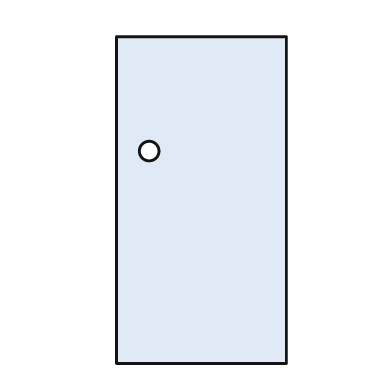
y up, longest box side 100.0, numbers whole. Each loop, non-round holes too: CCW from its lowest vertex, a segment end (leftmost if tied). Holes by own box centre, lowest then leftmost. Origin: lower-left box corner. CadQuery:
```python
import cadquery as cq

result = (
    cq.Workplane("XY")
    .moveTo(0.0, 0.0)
    .lineTo(52.0, 0.0)
    .lineTo(52.0, 100.0)
    .lineTo(0.0, 100.0)
    .close()
    .moveTo(10.0, 65.0)
    .circle(3.0)
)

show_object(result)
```